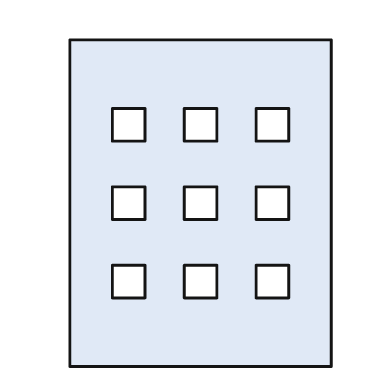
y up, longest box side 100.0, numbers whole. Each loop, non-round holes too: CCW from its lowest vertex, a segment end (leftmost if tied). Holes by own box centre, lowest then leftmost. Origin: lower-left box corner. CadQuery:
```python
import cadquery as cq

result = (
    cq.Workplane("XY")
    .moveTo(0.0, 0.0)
    .lineTo(80.0, 0.0)
    .lineTo(80.0, 100.0)
    .lineTo(0.0, 100.0)
    .close()
    .moveTo(13.0, 21.0)
    .lineTo(23.0, 21.0)
    .lineTo(23.0, 31.0)
    .lineTo(13.0, 31.0)
    .close()
    .moveTo(35.0, 21.0)
    .lineTo(45.0, 21.0)
    .lineTo(45.0, 31.0)
    .lineTo(35.0, 31.0)
    .close()
    .moveTo(57.0, 21.0)
    .lineTo(67.0, 21.0)
    .lineTo(67.0, 31.0)
    .lineTo(57.0, 31.0)
    .close()
    .moveTo(13.0, 45.0)
    .lineTo(23.0, 45.0)
    .lineTo(23.0, 55.0)
    .lineTo(13.0, 55.0)
    .close()
    .moveTo(35.0, 45.0)
    .lineTo(45.0, 45.0)
    .lineTo(45.0, 55.0)
    .lineTo(35.0, 55.0)
    .close()
    .moveTo(57.0, 45.0)
    .lineTo(67.0, 45.0)
    .lineTo(67.0, 55.0)
    .lineTo(57.0, 55.0)
    .close()
    .moveTo(13.0, 69.0)
    .lineTo(23.0, 69.0)
    .lineTo(23.0, 79.0)
    .lineTo(13.0, 79.0)
    .close()
    .moveTo(35.0, 69.0)
    .lineTo(45.0, 69.0)
    .lineTo(45.0, 79.0)
    .lineTo(35.0, 79.0)
    .close()
    .moveTo(57.0, 69.0)
    .lineTo(67.0, 69.0)
    .lineTo(67.0, 79.0)
    .lineTo(57.0, 79.0)
    .close()
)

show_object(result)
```